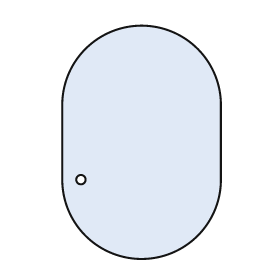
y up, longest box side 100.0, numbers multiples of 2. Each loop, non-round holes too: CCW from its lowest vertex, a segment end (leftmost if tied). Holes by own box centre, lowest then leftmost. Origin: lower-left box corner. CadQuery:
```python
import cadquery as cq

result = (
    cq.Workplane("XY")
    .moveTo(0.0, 34.0)
    .threePointArc((34.0, 0.0), (68.0, 34.0))
    .lineTo(68.0, 66.0)
    .threePointArc((34.0, 100.0), (0.0, 66.0))
    .close()
    .moveTo(8.0, 34.0)
    .circle(2.0)
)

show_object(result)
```